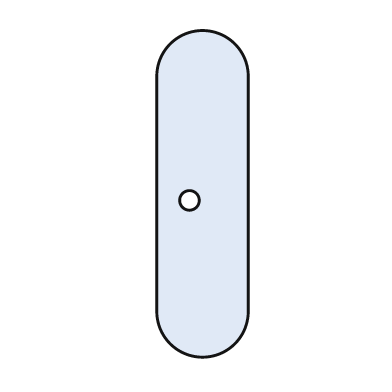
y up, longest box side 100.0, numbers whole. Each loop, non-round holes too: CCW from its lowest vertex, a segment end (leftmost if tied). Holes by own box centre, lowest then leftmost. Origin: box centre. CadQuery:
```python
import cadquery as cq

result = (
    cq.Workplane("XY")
    .moveTo(-14.0, -36.0)
    .threePointArc((0.0, -50.0), (14.0, -36.0))
    .lineTo(14.0, 36.0)
    .threePointArc((0.0, 50.0), (-14.0, 36.0))
    .close()
    .moveTo(-4.0, -2.0)
    .circle(3.0)
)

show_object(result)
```